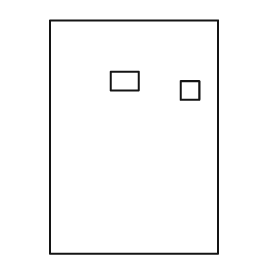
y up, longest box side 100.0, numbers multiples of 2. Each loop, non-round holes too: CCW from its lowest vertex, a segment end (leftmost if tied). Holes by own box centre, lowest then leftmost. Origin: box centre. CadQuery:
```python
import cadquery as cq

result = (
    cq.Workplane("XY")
    .moveTo(-36.0, -50.0)
    .lineTo(36.0, -50.0)
    .lineTo(36.0, 50.0)
    .lineTo(-36.0, 50.0)
    .close()
    .moveTo(20.0, 16.0)
    .lineTo(28.0, 16.0)
    .lineTo(28.0, 24.0)
    .lineTo(20.0, 24.0)
    .close()
    .moveTo(-10.0, 20.0)
    .lineTo(2.0, 20.0)
    .lineTo(2.0, 28.0)
    .lineTo(-10.0, 28.0)
    .close()
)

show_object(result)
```